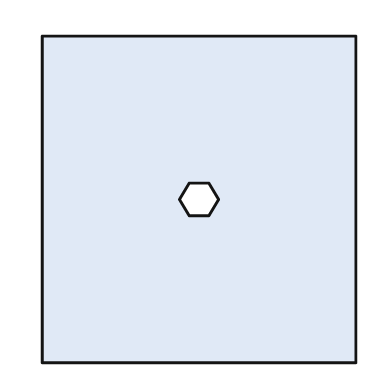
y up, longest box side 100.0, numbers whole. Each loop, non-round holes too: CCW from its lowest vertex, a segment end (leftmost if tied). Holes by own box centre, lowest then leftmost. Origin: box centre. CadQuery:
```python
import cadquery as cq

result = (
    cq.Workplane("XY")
    .moveTo(-48.0, -50.0)
    .lineTo(48.0, -50.0)
    .lineTo(48.0, 50.0)
    .lineTo(-48.0, 50.0)
    .close()
    .moveTo(-3.0, -5.0)
    .lineTo(3.0, -5.0)
    .lineTo(6.0, 0.0)
    .lineTo(3.0, 5.0)
    .lineTo(-3.0, 5.0)
    .lineTo(-6.0, 0.0)
    .close()
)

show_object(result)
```